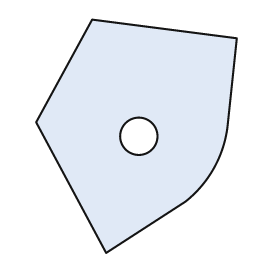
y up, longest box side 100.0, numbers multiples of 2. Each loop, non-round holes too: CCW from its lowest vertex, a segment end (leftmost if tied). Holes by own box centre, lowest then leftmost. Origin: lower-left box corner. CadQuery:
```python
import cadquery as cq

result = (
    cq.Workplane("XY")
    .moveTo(30.0, 0.0)
    .lineTo(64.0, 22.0)
    .threePointArc((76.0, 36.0), (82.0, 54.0))
    .lineTo(86.0, 92.0)
    .lineTo(24.0, 100.0)
    .lineTo(0.0, 56.0)
    .close()
    .moveTo(44.0, 50.0)
    .circle(8.0)
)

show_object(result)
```